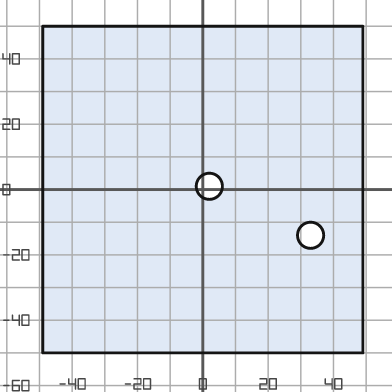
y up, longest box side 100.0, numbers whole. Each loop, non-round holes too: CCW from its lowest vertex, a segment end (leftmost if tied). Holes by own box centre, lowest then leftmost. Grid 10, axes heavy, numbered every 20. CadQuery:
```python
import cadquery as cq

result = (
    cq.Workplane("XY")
    .moveTo(-49.0, -50.0)
    .lineTo(49.0, -50.0)
    .lineTo(49.0, 50.0)
    .lineTo(-49.0, 50.0)
    .close()
    .moveTo(33.0, -14.0)
    .circle(4.0)
    .moveTo(2.0, 1.0)
    .circle(4.0)
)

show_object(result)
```